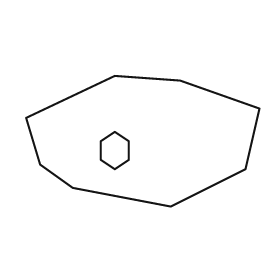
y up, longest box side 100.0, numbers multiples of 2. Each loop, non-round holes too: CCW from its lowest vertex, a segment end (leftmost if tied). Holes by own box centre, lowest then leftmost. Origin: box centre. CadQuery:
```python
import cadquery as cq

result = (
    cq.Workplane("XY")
    .moveTo(12.0, -28.0)
    .lineTo(44.0, -12.0)
    .lineTo(50.0, 14.0)
    .lineTo(16.0, 26.0)
    .lineTo(-12.0, 28.0)
    .lineTo(-50.0, 10.0)
    .lineTo(-44.0, -10.0)
    .lineTo(-30.0, -20.0)
    .close()
    .moveTo(-12.0, -12.0)
    .lineTo(-6.0, -8.0)
    .lineTo(-6.0, 0.0)
    .lineTo(-12.0, 4.0)
    .lineTo(-18.0, 0.0)
    .lineTo(-18.0, -8.0)
    .close()
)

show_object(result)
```